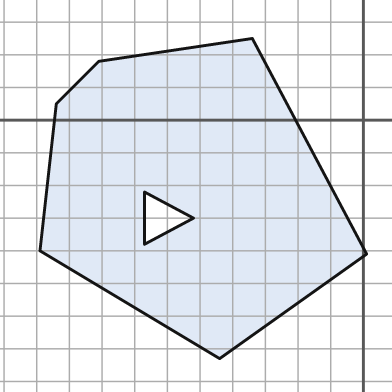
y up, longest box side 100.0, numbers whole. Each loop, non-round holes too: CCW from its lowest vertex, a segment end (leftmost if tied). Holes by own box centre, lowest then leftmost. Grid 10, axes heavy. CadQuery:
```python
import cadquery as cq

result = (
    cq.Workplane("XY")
    .moveTo(-44.0, -73.0)
    .lineTo(1.0, -41.0)
    .lineTo(-34.0, 25.0)
    .lineTo(-81.0, 18.0)
    .lineTo(-94.0, 5.0)
    .lineTo(-99.0, -40.0)
    .close()
    .moveTo(-67.0, -38.0)
    .lineTo(-52.0, -30.0)
    .lineTo(-67.0, -22.0)
    .close()
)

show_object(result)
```